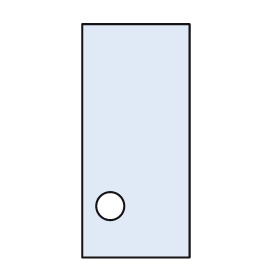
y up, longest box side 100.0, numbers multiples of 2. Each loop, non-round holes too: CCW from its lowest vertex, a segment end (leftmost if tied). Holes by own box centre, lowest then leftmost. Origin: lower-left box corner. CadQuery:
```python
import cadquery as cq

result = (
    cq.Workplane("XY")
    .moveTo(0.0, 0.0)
    .lineTo(46.0, 0.0)
    .lineTo(46.0, 100.0)
    .lineTo(0.0, 100.0)
    .close()
    .moveTo(12.0, 22.0)
    .circle(6.0)
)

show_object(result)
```